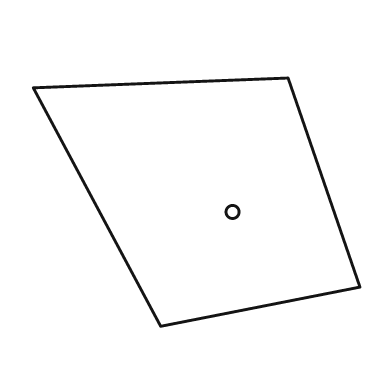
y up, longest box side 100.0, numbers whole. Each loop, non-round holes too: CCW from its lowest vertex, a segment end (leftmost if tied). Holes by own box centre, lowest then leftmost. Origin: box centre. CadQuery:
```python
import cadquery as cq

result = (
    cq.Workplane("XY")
    .moveTo(-11.0, -38.0)
    .lineTo(50.0, -26.0)
    .lineTo(28.0, 38.0)
    .lineTo(-50.0, 35.0)
    .close()
    .moveTo(11.0, -3.0)
    .circle(2.0)
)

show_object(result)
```